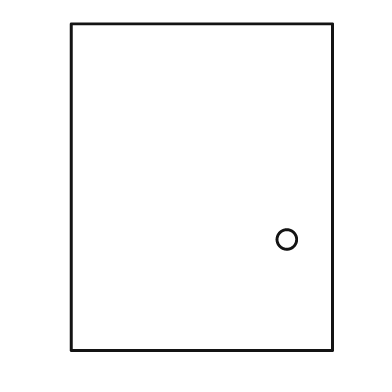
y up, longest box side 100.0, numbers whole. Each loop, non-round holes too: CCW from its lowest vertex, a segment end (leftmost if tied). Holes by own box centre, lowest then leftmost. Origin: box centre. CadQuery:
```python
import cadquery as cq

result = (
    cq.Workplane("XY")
    .moveTo(-40.0, -50.0)
    .lineTo(40.0, -50.0)
    .lineTo(40.0, 50.0)
    .lineTo(-40.0, 50.0)
    .close()
    .moveTo(26.0, -16.0)
    .circle(3.0)
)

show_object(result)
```